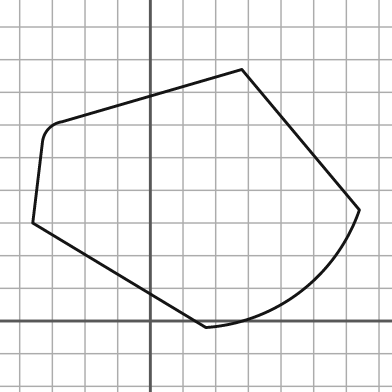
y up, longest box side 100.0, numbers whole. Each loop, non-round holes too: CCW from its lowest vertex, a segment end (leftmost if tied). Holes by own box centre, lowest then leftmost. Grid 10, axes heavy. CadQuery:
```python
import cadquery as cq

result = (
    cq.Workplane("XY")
    .moveTo(17.0, -2.0)
    .threePointArc((46.0, 9.0), (64.0, 34.0))
    .lineTo(28.0, 77.0)
    .lineTo(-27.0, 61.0)
    .threePointArc((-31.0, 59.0), (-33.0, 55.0))
    .lineTo(-36.0, 30.0)
    .close()
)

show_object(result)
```